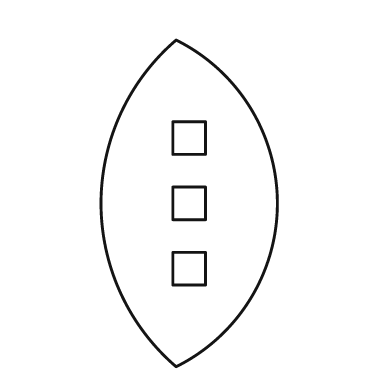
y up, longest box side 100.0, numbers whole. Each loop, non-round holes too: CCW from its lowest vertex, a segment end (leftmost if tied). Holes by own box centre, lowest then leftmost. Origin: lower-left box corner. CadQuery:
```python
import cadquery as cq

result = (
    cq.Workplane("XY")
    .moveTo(23.0, 0.0)
    .threePointArc((54.0, 50.0), (23.0, 100.0))
    .threePointArc((0.0, 50.0), (23.0, 0.0))
    .close()
    .moveTo(22.0, 25.0)
    .lineTo(32.0, 25.0)
    .lineTo(32.0, 35.0)
    .lineTo(22.0, 35.0)
    .close()
    .moveTo(22.0, 45.0)
    .lineTo(32.0, 45.0)
    .lineTo(32.0, 55.0)
    .lineTo(22.0, 55.0)
    .close()
    .moveTo(22.0, 65.0)
    .lineTo(32.0, 65.0)
    .lineTo(32.0, 75.0)
    .lineTo(22.0, 75.0)
    .close()
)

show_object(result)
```